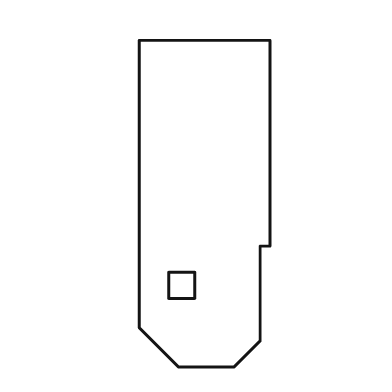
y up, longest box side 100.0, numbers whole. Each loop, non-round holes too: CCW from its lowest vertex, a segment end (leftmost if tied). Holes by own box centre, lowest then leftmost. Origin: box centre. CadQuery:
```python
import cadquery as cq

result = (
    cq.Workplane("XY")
    .moveTo(-8.0, -50.0)
    .lineTo(9.0, -50.0)
    .lineTo(17.0, -42.0)
    .lineTo(17.0, -13.0)
    .lineTo(20.0, -13.0)
    .lineTo(20.0, 50.0)
    .lineTo(-20.0, 50.0)
    .lineTo(-20.0, -38.0)
    .close()
    .moveTo(-11.0, -29.0)
    .lineTo(-3.0, -29.0)
    .lineTo(-3.0, -21.0)
    .lineTo(-11.0, -21.0)
    .close()
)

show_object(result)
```